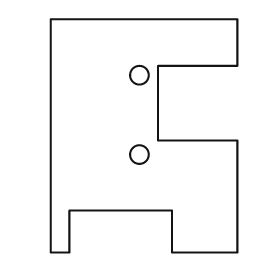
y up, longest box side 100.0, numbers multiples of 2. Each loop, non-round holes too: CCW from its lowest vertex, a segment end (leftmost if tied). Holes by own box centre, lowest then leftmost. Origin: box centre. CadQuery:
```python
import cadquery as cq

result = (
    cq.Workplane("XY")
    .moveTo(-40.0, -50.0)
    .lineTo(-32.0, -50.0)
    .lineTo(-32.0, -32.0)
    .lineTo(12.0, -32.0)
    .lineTo(12.0, -50.0)
    .lineTo(40.0, -50.0)
    .lineTo(40.0, -2.0)
    .lineTo(6.0, -2.0)
    .lineTo(6.0, 30.0)
    .lineTo(40.0, 30.0)
    .lineTo(40.0, 50.0)
    .lineTo(-40.0, 50.0)
    .close()
    .moveTo(-2.0, -8.0)
    .circle(4.0)
    .moveTo(-2.0, 26.0)
    .circle(4.0)
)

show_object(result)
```